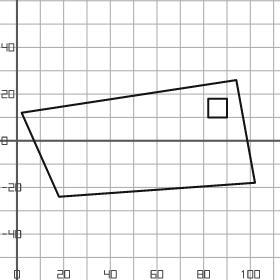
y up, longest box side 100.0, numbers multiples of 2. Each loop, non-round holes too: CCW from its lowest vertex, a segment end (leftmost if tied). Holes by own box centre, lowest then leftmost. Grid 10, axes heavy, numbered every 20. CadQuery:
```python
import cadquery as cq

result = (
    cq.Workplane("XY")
    .moveTo(18.0, -24.0)
    .lineTo(102.0, -18.0)
    .lineTo(94.0, 26.0)
    .lineTo(2.0, 12.0)
    .close()
    .moveTo(82.0, 10.0)
    .lineTo(90.0, 10.0)
    .lineTo(90.0, 18.0)
    .lineTo(82.0, 18.0)
    .close()
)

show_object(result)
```